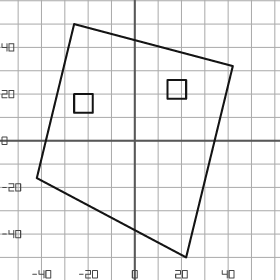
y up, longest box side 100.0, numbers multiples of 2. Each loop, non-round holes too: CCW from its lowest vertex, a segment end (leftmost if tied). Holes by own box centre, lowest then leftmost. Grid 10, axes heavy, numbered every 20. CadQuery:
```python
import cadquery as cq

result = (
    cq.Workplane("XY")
    .moveTo(22.0, -50.0)
    .lineTo(42.0, 32.0)
    .lineTo(-26.0, 50.0)
    .lineTo(-42.0, -16.0)
    .close()
    .moveTo(-26.0, 12.0)
    .lineTo(-18.0, 12.0)
    .lineTo(-18.0, 20.0)
    .lineTo(-26.0, 20.0)
    .close()
    .moveTo(14.0, 18.0)
    .lineTo(22.0, 18.0)
    .lineTo(22.0, 26.0)
    .lineTo(14.0, 26.0)
    .close()
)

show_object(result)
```